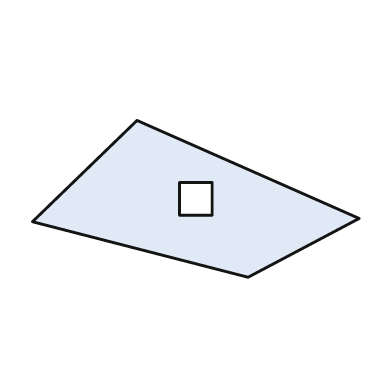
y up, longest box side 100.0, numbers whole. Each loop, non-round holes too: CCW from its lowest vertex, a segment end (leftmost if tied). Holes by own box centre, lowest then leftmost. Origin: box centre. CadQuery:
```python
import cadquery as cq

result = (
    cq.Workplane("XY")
    .moveTo(16.0, -24.0)
    .lineTo(50.0, -6.0)
    .lineTo(-18.0, 24.0)
    .lineTo(-50.0, -7.0)
    .close()
    .moveTo(-5.0, -5.0)
    .lineTo(5.0, -5.0)
    .lineTo(5.0, 5.0)
    .lineTo(-5.0, 5.0)
    .close()
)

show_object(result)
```